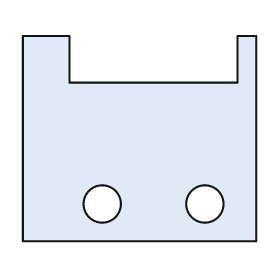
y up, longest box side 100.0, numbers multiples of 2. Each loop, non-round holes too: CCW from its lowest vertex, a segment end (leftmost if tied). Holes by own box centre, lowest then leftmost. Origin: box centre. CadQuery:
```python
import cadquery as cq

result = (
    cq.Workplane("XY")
    .moveTo(-50.0, -44.0)
    .lineTo(50.0, -44.0)
    .lineTo(50.0, 44.0)
    .lineTo(42.0, 44.0)
    .lineTo(42.0, 24.0)
    .lineTo(-30.0, 24.0)
    .lineTo(-30.0, 44.0)
    .lineTo(-50.0, 44.0)
    .close()
    .moveTo(-16.0, -28.0)
    .circle(8.0)
    .moveTo(28.0, -28.0)
    .circle(8.0)
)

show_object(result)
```